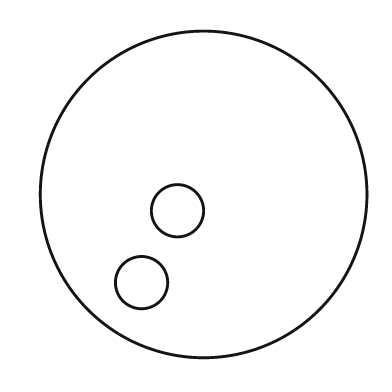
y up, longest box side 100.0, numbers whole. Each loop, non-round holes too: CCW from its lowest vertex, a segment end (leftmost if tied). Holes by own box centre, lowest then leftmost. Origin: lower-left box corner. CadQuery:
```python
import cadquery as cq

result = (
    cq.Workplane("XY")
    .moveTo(50.0, 50.0)
    .circle(50.0)
    .moveTo(31.0, 23.0)
    .circle(8.0)
    .moveTo(42.0, 45.0)
    .circle(8.0)
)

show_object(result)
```